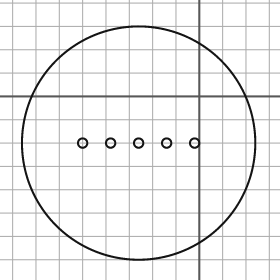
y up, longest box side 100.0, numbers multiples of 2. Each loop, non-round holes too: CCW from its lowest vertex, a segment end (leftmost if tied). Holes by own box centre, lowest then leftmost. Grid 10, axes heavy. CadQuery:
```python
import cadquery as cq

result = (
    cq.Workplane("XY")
    .moveTo(-26.0, -20.0)
    .circle(50.0)
    .moveTo(-50.0, -20.0)
    .circle(2.0)
    .moveTo(-38.0, -20.0)
    .circle(2.0)
    .moveTo(-26.0, -20.0)
    .circle(2.0)
    .moveTo(-14.0, -20.0)
    .circle(2.0)
    .moveTo(-2.0, -20.0)
    .circle(2.0)
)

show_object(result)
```